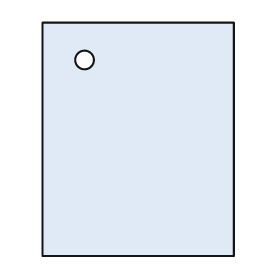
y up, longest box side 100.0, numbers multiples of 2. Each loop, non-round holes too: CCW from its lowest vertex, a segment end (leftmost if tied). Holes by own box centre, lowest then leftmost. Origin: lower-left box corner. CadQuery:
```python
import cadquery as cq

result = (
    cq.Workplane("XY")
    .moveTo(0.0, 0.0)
    .lineTo(82.0, 0.0)
    .lineTo(82.0, 100.0)
    .lineTo(0.0, 100.0)
    .close()
    .moveTo(18.0, 84.0)
    .circle(4.0)
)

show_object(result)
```